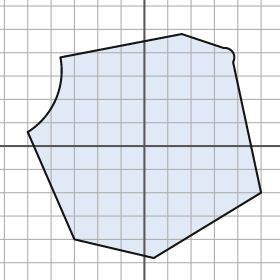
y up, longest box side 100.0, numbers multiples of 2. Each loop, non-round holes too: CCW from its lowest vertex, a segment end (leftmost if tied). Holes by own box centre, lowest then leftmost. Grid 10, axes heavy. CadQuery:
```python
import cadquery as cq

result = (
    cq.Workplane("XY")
    .moveTo(4.0, -48.0)
    .lineTo(50.0, -20.0)
    .lineTo(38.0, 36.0)
    .threePointArc((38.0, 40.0), (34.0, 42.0))
    .lineTo(16.0, 48.0)
    .lineTo(-36.0, 38.0)
    .threePointArc((-38.0, 20.0), (-50.0, 6.0))
    .lineTo(-30.0, -40.0)
    .close()
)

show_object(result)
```